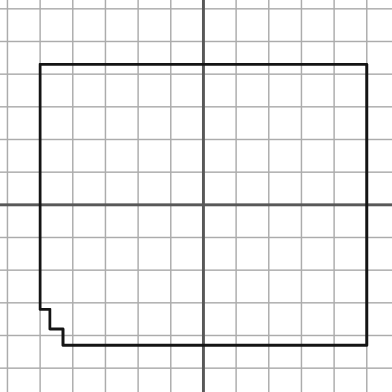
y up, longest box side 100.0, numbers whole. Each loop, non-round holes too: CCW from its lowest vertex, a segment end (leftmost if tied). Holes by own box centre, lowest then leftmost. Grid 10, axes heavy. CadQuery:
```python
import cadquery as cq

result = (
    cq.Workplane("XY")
    .moveTo(-43.0, -43.0)
    .lineTo(50.0, -43.0)
    .lineTo(50.0, 43.0)
    .lineTo(-50.0, 43.0)
    .lineTo(-50.0, -32.0)
    .lineTo(-47.0, -32.0)
    .lineTo(-47.0, -38.0)
    .lineTo(-43.0, -38.0)
    .close()
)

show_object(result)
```